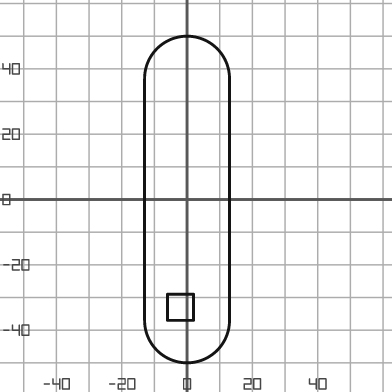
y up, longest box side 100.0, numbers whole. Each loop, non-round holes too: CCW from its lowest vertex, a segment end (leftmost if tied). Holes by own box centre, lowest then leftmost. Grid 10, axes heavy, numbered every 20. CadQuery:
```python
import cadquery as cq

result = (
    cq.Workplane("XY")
    .moveTo(-13.0, -37.0)
    .threePointArc((0.0, -50.0), (13.0, -37.0))
    .lineTo(13.0, 37.0)
    .threePointArc((0.0, 50.0), (-13.0, 37.0))
    .close()
    .moveTo(-6.0, -37.0)
    .lineTo(2.0, -37.0)
    .lineTo(2.0, -29.0)
    .lineTo(-6.0, -29.0)
    .close()
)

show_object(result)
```